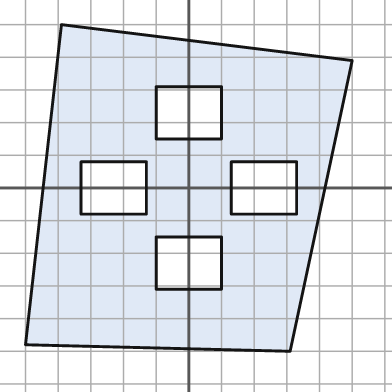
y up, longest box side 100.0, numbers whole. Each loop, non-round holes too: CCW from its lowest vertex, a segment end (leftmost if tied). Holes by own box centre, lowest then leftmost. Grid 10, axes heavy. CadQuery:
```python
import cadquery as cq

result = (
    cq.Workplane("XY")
    .moveTo(31.0, -50.0)
    .lineTo(50.0, 39.0)
    .lineTo(-39.0, 50.0)
    .lineTo(-50.0, -48.0)
    .close()
    .moveTo(-10.0, -31.0)
    .lineTo(10.0, -31.0)
    .lineTo(10.0, -15.0)
    .lineTo(-10.0, -15.0)
    .close()
    .moveTo(-33.0, -8.0)
    .lineTo(-13.0, -8.0)
    .lineTo(-13.0, 8.0)
    .lineTo(-33.0, 8.0)
    .close()
    .moveTo(13.0, -8.0)
    .lineTo(33.0, -8.0)
    .lineTo(33.0, 8.0)
    .lineTo(13.0, 8.0)
    .close()
    .moveTo(-10.0, 15.0)
    .lineTo(10.0, 15.0)
    .lineTo(10.0, 31.0)
    .lineTo(-10.0, 31.0)
    .close()
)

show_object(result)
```